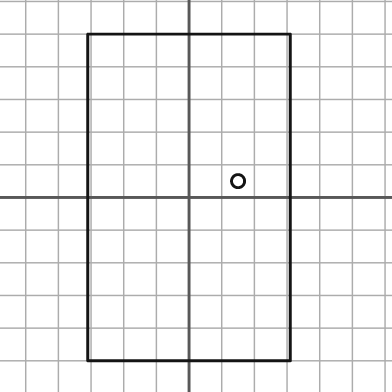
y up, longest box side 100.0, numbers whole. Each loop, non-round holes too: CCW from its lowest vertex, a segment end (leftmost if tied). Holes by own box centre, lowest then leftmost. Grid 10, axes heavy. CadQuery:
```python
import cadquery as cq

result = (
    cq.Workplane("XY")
    .moveTo(-31.0, -50.0)
    .lineTo(31.0, -50.0)
    .lineTo(31.0, 50.0)
    .lineTo(-31.0, 50.0)
    .close()
    .moveTo(15.0, 5.0)
    .circle(2.0)
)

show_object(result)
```